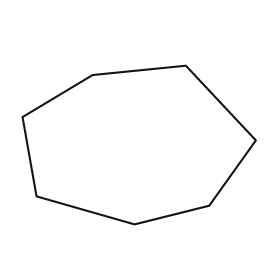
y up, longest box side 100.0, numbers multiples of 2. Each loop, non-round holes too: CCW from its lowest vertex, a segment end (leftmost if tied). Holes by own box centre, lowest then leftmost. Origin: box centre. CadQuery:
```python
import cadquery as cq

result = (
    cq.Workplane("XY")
    .moveTo(-2.0, -34.0)
    .lineTo(30.0, -26.0)
    .lineTo(50.0, 2.0)
    .lineTo(20.0, 34.0)
    .lineTo(-20.0, 30.0)
    .lineTo(-50.0, 12.0)
    .lineTo(-44.0, -22.0)
    .close()
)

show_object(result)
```